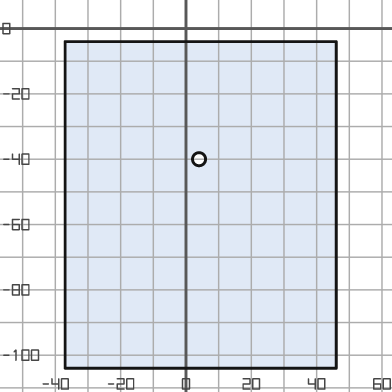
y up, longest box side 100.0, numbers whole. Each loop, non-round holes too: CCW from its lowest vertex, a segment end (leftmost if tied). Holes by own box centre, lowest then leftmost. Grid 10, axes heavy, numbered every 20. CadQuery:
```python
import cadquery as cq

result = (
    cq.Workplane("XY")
    .moveTo(-37.0, -104.0)
    .lineTo(46.0, -104.0)
    .lineTo(46.0, -4.0)
    .lineTo(-37.0, -4.0)
    .close()
    .moveTo(4.0, -40.0)
    .circle(2.0)
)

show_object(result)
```